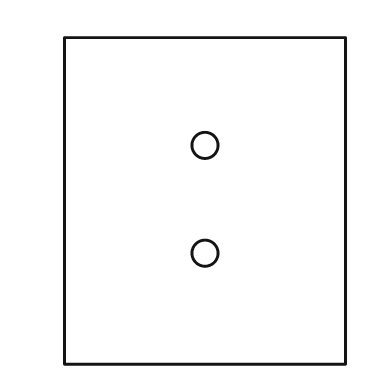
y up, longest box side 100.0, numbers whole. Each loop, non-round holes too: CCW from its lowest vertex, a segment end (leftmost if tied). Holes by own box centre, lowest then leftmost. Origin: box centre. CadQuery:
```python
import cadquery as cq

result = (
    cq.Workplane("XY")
    .moveTo(-43.0, -50.0)
    .lineTo(43.0, -50.0)
    .lineTo(43.0, 50.0)
    .lineTo(-43.0, 50.0)
    .close()
    .moveTo(0.0, -16.0)
    .circle(4.0)
    .moveTo(0.0, 17.0)
    .circle(4.0)
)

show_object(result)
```